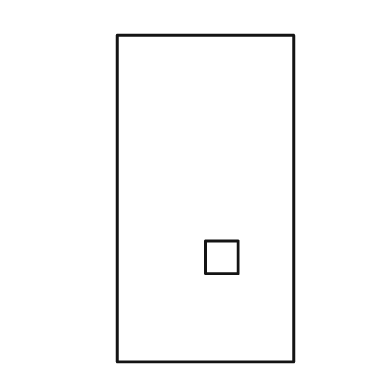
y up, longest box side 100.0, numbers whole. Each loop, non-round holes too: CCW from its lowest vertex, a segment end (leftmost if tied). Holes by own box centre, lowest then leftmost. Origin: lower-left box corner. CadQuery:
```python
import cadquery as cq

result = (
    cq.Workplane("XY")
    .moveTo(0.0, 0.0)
    .lineTo(54.0, 0.0)
    .lineTo(54.0, 100.0)
    .lineTo(0.0, 100.0)
    .close()
    .moveTo(27.0, 27.0)
    .lineTo(37.0, 27.0)
    .lineTo(37.0, 37.0)
    .lineTo(27.0, 37.0)
    .close()
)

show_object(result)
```